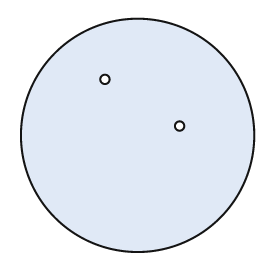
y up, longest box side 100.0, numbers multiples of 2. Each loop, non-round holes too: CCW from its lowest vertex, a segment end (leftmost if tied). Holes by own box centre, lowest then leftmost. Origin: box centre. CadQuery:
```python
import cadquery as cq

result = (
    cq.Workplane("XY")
    .moveTo(0.0, 0.0)
    .circle(50.0)
    .moveTo(18.0, 4.0)
    .circle(2.0)
    .moveTo(-14.0, 24.0)
    .circle(2.0)
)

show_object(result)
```